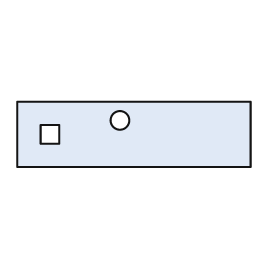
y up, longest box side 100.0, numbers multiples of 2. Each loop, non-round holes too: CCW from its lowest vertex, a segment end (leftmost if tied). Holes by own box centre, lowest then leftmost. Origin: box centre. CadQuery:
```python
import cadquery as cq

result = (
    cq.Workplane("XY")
    .moveTo(-50.0, -14.0)
    .lineTo(50.0, -14.0)
    .lineTo(50.0, 14.0)
    .lineTo(-50.0, 14.0)
    .close()
    .moveTo(-40.0, -4.0)
    .lineTo(-32.0, -4.0)
    .lineTo(-32.0, 4.0)
    .lineTo(-40.0, 4.0)
    .close()
    .moveTo(-6.0, 6.0)
    .circle(4.0)
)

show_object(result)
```